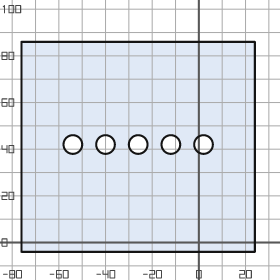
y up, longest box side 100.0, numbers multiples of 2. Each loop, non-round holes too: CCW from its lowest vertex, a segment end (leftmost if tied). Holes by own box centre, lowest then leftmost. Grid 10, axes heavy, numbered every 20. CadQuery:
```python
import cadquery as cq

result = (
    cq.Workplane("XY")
    .moveTo(-76.0, -4.0)
    .lineTo(24.0, -4.0)
    .lineTo(24.0, 86.0)
    .lineTo(-76.0, 86.0)
    .close()
    .moveTo(-54.0, 42.0)
    .circle(4.0)
    .moveTo(-40.0, 42.0)
    .circle(4.0)
    .moveTo(-26.0, 42.0)
    .circle(4.0)
    .moveTo(-12.0, 42.0)
    .circle(4.0)
    .moveTo(2.0, 42.0)
    .circle(4.0)
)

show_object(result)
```